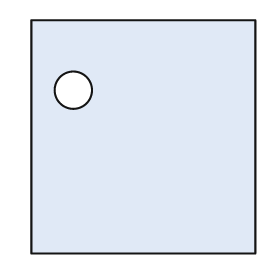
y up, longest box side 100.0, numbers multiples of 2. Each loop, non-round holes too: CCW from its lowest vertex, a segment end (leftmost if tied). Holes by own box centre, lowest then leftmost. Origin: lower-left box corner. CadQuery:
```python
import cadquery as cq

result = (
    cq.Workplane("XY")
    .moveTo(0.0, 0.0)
    .lineTo(96.0, 0.0)
    .lineTo(96.0, 100.0)
    .lineTo(0.0, 100.0)
    .close()
    .moveTo(18.0, 70.0)
    .circle(8.0)
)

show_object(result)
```